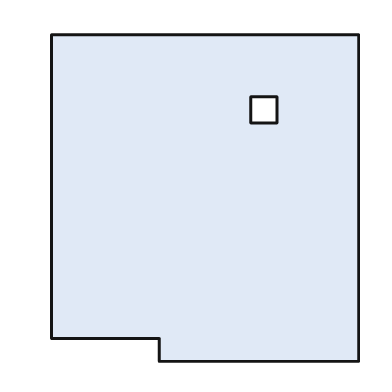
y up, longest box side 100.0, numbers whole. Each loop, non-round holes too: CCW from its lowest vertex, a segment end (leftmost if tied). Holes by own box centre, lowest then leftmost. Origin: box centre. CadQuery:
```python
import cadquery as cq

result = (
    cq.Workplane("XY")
    .moveTo(-14.0, -50.0)
    .lineTo(47.0, -50.0)
    .lineTo(47.0, 50.0)
    .lineTo(-47.0, 50.0)
    .lineTo(-47.0, -43.0)
    .lineTo(-14.0, -43.0)
    .close()
    .moveTo(14.0, 23.0)
    .lineTo(22.0, 23.0)
    .lineTo(22.0, 31.0)
    .lineTo(14.0, 31.0)
    .close()
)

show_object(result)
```